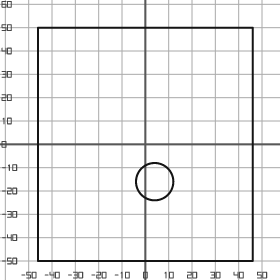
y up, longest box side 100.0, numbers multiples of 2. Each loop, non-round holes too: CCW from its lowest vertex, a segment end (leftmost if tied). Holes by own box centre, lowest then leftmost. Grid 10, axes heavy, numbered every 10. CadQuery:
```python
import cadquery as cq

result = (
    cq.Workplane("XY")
    .moveTo(-46.0, -50.0)
    .lineTo(46.0, -50.0)
    .lineTo(46.0, 50.0)
    .lineTo(-46.0, 50.0)
    .close()
    .moveTo(4.0, -16.0)
    .circle(8.0)
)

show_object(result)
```